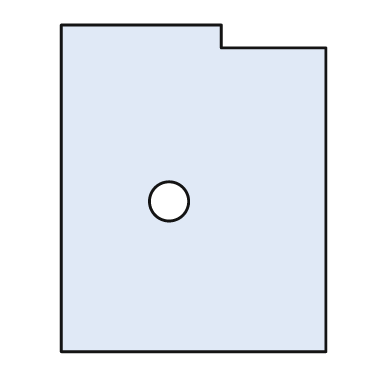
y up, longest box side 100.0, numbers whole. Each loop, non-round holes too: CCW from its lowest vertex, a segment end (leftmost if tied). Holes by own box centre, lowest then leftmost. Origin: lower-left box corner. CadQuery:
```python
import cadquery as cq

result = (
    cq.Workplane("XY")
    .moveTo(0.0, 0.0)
    .lineTo(81.0, 0.0)
    .lineTo(81.0, 93.0)
    .lineTo(49.0, 93.0)
    .lineTo(49.0, 100.0)
    .lineTo(0.0, 100.0)
    .close()
    .moveTo(33.0, 46.0)
    .circle(6.0)
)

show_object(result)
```